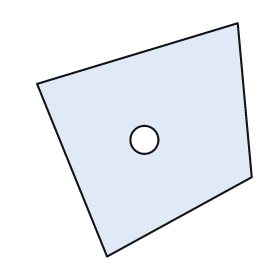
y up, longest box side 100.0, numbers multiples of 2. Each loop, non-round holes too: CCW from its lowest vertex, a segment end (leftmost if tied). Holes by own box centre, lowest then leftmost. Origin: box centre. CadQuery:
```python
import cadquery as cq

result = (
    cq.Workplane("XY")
    .moveTo(-16.0, -50.0)
    .lineTo(46.0, -16.0)
    .lineTo(40.0, 50.0)
    .lineTo(-46.0, 24.0)
    .close()
    .moveTo(0.0, 0.0)
    .circle(6.0)
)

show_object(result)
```